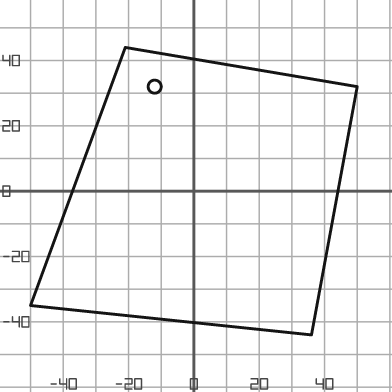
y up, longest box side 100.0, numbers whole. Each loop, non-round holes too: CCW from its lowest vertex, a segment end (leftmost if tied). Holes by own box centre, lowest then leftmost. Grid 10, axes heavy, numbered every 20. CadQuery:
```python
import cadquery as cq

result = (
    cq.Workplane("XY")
    .moveTo(36.0, -44.0)
    .lineTo(50.0, 32.0)
    .lineTo(-21.0, 44.0)
    .lineTo(-50.0, -35.0)
    .close()
    .moveTo(-12.0, 32.0)
    .circle(2.0)
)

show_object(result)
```